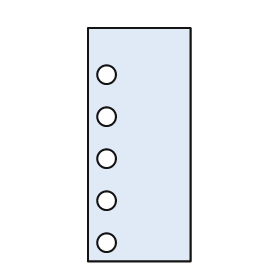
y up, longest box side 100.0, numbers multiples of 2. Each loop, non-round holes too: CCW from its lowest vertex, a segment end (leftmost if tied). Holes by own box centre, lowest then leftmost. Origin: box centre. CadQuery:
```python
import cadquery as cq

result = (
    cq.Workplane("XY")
    .moveTo(-22.0, -50.0)
    .lineTo(22.0, -50.0)
    .lineTo(22.0, 50.0)
    .lineTo(-22.0, 50.0)
    .close()
    .moveTo(-14.0, -42.0)
    .circle(4.0)
    .moveTo(-14.0, -24.0)
    .circle(4.0)
    .moveTo(-14.0, -6.0)
    .circle(4.0)
    .moveTo(-14.0, 12.0)
    .circle(4.0)
    .moveTo(-14.0, 30.0)
    .circle(4.0)
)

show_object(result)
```